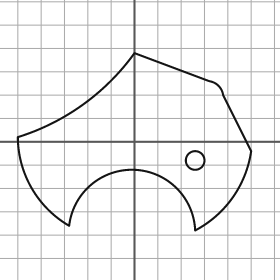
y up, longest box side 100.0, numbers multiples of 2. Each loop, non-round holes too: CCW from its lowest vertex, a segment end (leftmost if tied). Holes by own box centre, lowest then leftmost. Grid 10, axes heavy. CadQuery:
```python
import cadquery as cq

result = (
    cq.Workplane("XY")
    .moveTo(26.0, -38.0)
    .threePointArc((42.0, -24.0), (50.0, -4.0))
    .lineTo(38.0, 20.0)
    .threePointArc((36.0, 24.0), (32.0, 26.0))
    .lineTo(0.0, 38.0)
    .threePointArc((-22.0, 16.0), (-50.0, 2.0))
    .threePointArc((-44.0, -20.0), (-28.0, -36.0))
    .threePointArc((0.0, -12.0), (26.0, -38.0))
    .close()
    .moveTo(26.0, -8.0)
    .circle(4.0)
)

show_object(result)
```